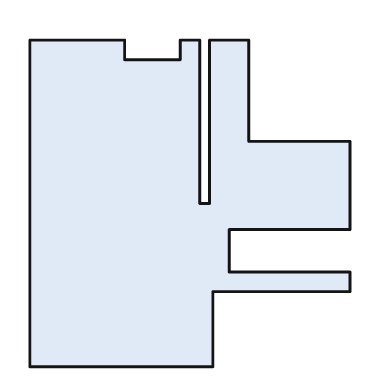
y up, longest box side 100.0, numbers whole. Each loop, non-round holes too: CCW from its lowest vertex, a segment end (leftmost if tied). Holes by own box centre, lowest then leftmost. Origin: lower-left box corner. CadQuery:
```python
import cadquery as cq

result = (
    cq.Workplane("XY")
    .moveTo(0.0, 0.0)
    .lineTo(56.0, 0.0)
    .lineTo(56.0, 23.0)
    .lineTo(98.0, 23.0)
    .lineTo(98.0, 29.0)
    .lineTo(61.0, 29.0)
    .lineTo(61.0, 42.0)
    .lineTo(98.0, 42.0)
    .lineTo(98.0, 69.0)
    .lineTo(67.0, 69.0)
    .lineTo(67.0, 100.0)
    .lineTo(55.0, 100.0)
    .lineTo(55.0, 50.0)
    .lineTo(52.0, 50.0)
    .lineTo(52.0, 100.0)
    .lineTo(46.0, 100.0)
    .lineTo(46.0, 94.0)
    .lineTo(29.0, 94.0)
    .lineTo(29.0, 100.0)
    .lineTo(0.0, 100.0)
    .close()
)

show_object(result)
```